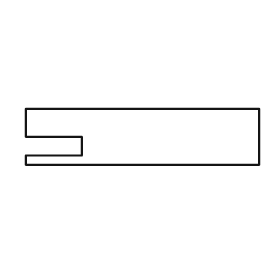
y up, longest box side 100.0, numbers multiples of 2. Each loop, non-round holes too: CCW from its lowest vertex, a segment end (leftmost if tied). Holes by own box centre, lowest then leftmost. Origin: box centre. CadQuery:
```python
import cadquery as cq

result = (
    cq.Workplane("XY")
    .moveTo(-50.0, -12.0)
    .lineTo(50.0, -12.0)
    .lineTo(50.0, 12.0)
    .lineTo(-50.0, 12.0)
    .lineTo(-50.0, 0.0)
    .lineTo(-26.0, 0.0)
    .lineTo(-26.0, -8.0)
    .lineTo(-50.0, -8.0)
    .close()
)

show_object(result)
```